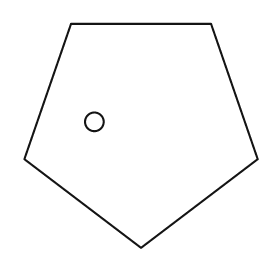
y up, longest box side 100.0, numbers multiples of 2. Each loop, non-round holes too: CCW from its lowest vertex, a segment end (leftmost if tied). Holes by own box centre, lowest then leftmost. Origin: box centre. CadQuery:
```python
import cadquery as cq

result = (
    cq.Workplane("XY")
    .moveTo(0.0, -48.0)
    .lineTo(50.0, -10.0)
    .lineTo(30.0, 48.0)
    .lineTo(-30.0, 48.0)
    .lineTo(-50.0, -10.0)
    .close()
    .moveTo(-20.0, 6.0)
    .circle(4.0)
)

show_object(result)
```